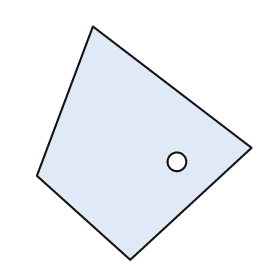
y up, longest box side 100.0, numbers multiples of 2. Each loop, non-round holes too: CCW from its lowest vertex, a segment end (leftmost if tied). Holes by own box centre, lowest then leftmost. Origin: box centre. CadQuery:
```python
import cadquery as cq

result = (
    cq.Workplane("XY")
    .moveTo(-6.0, -50.0)
    .lineTo(46.0, -2.0)
    .lineTo(-22.0, 50.0)
    .lineTo(-46.0, -14.0)
    .close()
    .moveTo(14.0, -8.0)
    .circle(4.0)
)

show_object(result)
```